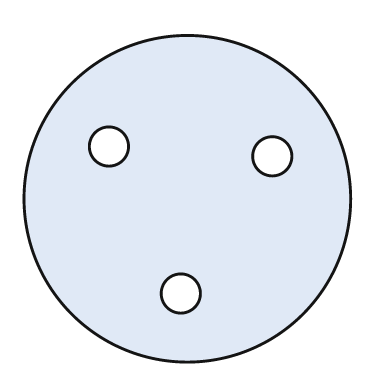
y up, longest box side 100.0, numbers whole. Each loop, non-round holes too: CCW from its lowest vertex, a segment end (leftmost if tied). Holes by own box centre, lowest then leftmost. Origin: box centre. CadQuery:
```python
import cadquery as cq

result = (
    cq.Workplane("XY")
    .moveTo(0.0, 0.0)
    .circle(50.0)
    .moveTo(-2.0, -29.0)
    .circle(6.0)
    .moveTo(26.0, 13.0)
    .circle(6.0)
    .moveTo(-24.0, 16.0)
    .circle(6.0)
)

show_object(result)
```